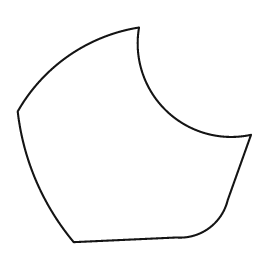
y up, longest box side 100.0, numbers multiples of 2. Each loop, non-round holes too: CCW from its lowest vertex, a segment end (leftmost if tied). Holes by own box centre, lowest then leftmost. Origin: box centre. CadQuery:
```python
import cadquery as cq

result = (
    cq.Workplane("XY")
    .moveTo(-26.0, -46.0)
    .lineTo(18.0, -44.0)
    .threePointArc((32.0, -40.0), (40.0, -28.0))
    .lineTo(50.0, 0.0)
    .threePointArc((14.0, 10.0), (2.0, 46.0))
    .threePointArc((-28.0, 34.0), (-50.0, 10.0))
    .threePointArc((-42.0, -20.0), (-26.0, -46.0))
    .close()
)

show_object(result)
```